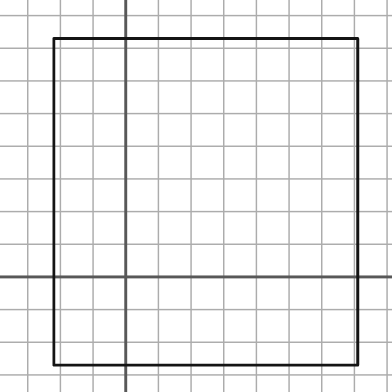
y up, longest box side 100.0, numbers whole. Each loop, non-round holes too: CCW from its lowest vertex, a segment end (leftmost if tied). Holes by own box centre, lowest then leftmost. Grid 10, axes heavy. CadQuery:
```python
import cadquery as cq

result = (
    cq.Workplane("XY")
    .moveTo(-22.0, -27.0)
    .lineTo(71.0, -27.0)
    .lineTo(71.0, 73.0)
    .lineTo(-22.0, 73.0)
    .close()
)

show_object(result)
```